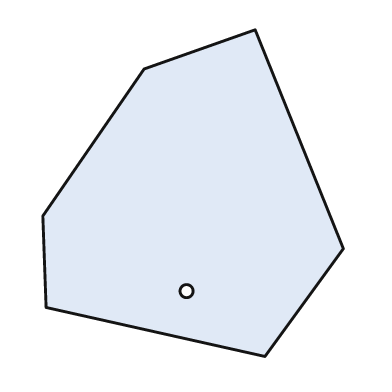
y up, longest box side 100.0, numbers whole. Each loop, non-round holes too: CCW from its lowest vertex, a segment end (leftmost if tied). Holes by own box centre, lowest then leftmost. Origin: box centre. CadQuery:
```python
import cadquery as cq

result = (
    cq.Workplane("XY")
    .moveTo(22.0, -50.0)
    .lineTo(46.0, -17.0)
    .lineTo(19.0, 50.0)
    .lineTo(-15.0, 38.0)
    .lineTo(-46.0, -7.0)
    .lineTo(-45.0, -35.0)
    .close()
    .moveTo(-2.0, -30.0)
    .circle(2.0)
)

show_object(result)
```